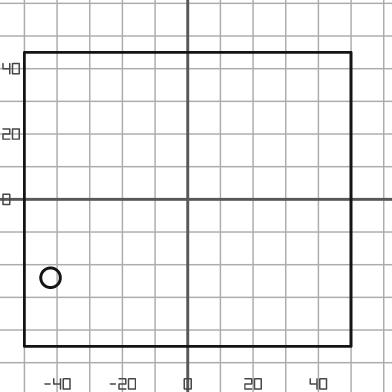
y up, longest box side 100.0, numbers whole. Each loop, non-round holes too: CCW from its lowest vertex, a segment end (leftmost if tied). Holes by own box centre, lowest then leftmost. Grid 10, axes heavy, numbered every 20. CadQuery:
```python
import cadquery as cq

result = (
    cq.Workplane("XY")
    .moveTo(-50.0, -45.0)
    .lineTo(50.0, -45.0)
    .lineTo(50.0, 45.0)
    .lineTo(-50.0, 45.0)
    .close()
    .moveTo(-42.0, -24.0)
    .circle(3.0)
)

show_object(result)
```